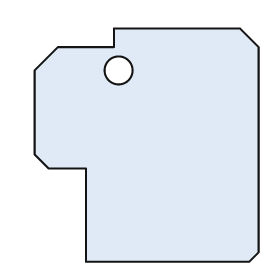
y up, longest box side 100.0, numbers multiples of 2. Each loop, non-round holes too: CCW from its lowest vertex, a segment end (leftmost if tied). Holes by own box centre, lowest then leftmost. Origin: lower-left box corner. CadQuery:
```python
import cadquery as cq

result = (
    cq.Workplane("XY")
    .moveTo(22.0, 0.0)
    .lineTo(92.0, 0.0)
    .lineTo(96.0, 4.0)
    .lineTo(96.0, 92.0)
    .lineTo(88.0, 100.0)
    .lineTo(34.0, 100.0)
    .lineTo(34.0, 92.0)
    .lineTo(10.0, 92.0)
    .lineTo(0.0, 82.0)
    .lineTo(0.0, 46.0)
    .lineTo(6.0, 40.0)
    .lineTo(22.0, 40.0)
    .close()
    .moveTo(36.0, 82.0)
    .circle(6.0)
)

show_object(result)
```